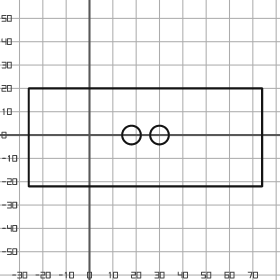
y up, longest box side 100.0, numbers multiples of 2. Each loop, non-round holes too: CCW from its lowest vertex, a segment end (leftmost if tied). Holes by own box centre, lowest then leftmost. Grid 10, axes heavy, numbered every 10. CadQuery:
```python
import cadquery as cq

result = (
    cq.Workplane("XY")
    .moveTo(-26.0, -22.0)
    .lineTo(74.0, -22.0)
    .lineTo(74.0, 20.0)
    .lineTo(-26.0, 20.0)
    .close()
    .moveTo(18.0, 0.0)
    .circle(4.0)
    .moveTo(30.0, 0.0)
    .circle(4.0)
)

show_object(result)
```